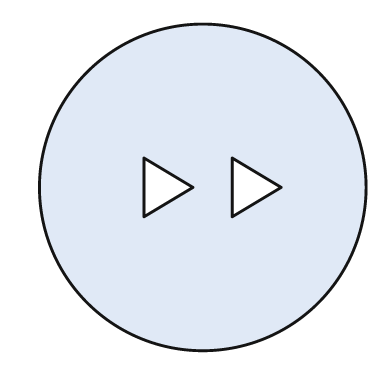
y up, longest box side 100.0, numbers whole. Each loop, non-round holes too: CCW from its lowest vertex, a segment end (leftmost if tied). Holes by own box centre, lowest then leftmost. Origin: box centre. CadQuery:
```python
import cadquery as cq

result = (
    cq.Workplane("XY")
    .moveTo(0.0, 0.0)
    .circle(50.0)
    .moveTo(-18.0, -9.0)
    .lineTo(-3.0, 0.0)
    .lineTo(-18.0, 9.0)
    .close()
    .moveTo(9.0, -9.0)
    .lineTo(24.0, 0.0)
    .lineTo(9.0, 9.0)
    .close()
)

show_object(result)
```